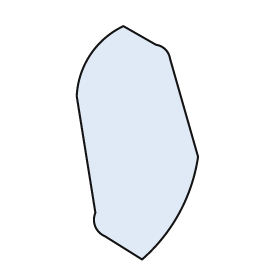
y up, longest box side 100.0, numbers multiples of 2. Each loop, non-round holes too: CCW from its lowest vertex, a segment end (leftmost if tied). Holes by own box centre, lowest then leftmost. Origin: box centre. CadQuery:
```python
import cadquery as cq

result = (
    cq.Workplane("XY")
    .moveTo(2.0, -50.0)
    .threePointArc((18.0, -30.0), (26.0, -6.0))
    .lineTo(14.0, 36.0)
    .threePointArc((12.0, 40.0), (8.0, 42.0))
    .lineTo(-6.0, 50.0)
    .threePointArc((-20.0, 38.0), (-26.0, 20.0))
    .lineTo(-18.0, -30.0)
    .threePointArc((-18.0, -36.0), (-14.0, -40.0))
    .close()
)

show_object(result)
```